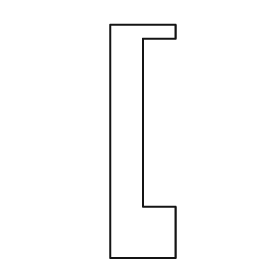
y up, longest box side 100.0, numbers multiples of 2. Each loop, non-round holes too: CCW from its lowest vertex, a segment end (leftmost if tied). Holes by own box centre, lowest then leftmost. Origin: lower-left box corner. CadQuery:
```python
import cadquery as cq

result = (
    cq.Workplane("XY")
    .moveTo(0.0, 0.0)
    .lineTo(28.0, 0.0)
    .lineTo(28.0, 22.0)
    .lineTo(14.0, 22.0)
    .lineTo(14.0, 94.0)
    .lineTo(28.0, 94.0)
    .lineTo(28.0, 100.0)
    .lineTo(0.0, 100.0)
    .close()
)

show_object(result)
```